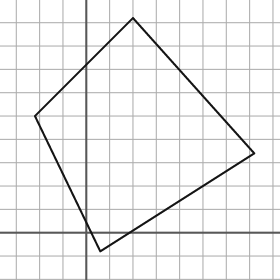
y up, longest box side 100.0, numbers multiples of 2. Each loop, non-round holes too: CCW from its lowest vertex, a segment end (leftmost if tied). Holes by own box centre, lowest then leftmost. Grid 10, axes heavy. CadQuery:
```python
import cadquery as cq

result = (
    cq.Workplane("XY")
    .moveTo(6.0, -8.0)
    .lineTo(72.0, 34.0)
    .lineTo(20.0, 92.0)
    .lineTo(-22.0, 50.0)
    .close()
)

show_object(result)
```